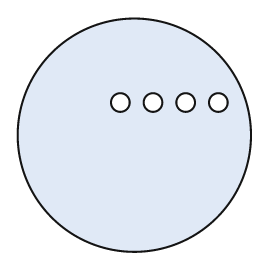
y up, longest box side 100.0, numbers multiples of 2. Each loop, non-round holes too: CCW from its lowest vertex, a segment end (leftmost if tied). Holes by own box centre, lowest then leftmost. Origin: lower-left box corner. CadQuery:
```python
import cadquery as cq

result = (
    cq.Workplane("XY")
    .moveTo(50.0, 50.0)
    .circle(50.0)
    .moveTo(44.0, 64.0)
    .circle(4.0)
    .moveTo(58.0, 64.0)
    .circle(4.0)
    .moveTo(72.0, 64.0)
    .circle(4.0)
    .moveTo(86.0, 64.0)
    .circle(4.0)
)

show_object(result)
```